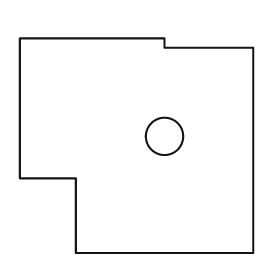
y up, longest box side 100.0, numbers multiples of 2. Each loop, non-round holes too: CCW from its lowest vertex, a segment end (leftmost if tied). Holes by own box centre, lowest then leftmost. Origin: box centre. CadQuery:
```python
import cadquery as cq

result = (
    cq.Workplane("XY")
    .moveTo(-26.0, -46.0)
    .lineTo(50.0, -46.0)
    .lineTo(50.0, 42.0)
    .lineTo(12.0, 42.0)
    .lineTo(12.0, 46.0)
    .lineTo(-50.0, 46.0)
    .lineTo(-50.0, -14.0)
    .lineTo(-26.0, -14.0)
    .close()
    .moveTo(12.0, 4.0)
    .circle(8.0)
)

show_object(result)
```